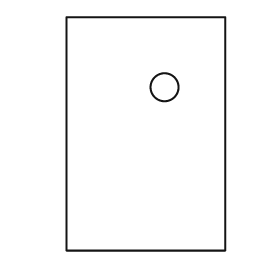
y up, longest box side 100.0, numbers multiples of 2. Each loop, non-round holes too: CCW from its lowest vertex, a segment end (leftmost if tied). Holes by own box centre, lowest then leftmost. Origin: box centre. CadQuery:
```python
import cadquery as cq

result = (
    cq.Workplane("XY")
    .moveTo(-34.0, -50.0)
    .lineTo(34.0, -50.0)
    .lineTo(34.0, 50.0)
    .lineTo(-34.0, 50.0)
    .close()
    .moveTo(8.0, 20.0)
    .circle(6.0)
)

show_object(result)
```